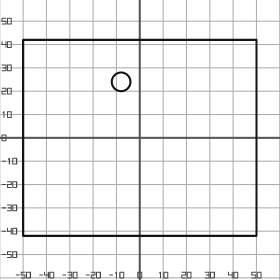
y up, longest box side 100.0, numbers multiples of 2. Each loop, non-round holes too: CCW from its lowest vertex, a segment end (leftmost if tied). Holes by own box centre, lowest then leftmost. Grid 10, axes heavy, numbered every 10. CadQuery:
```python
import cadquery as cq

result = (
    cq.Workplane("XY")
    .moveTo(-50.0, -42.0)
    .lineTo(50.0, -42.0)
    .lineTo(50.0, 42.0)
    .lineTo(-50.0, 42.0)
    .close()
    .moveTo(-8.0, 24.0)
    .circle(4.0)
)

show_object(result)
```